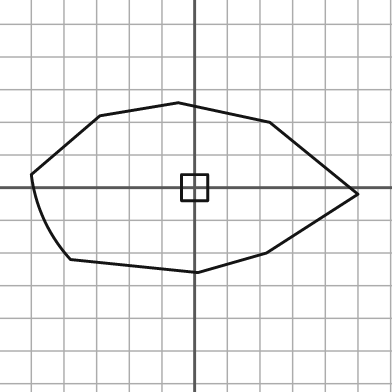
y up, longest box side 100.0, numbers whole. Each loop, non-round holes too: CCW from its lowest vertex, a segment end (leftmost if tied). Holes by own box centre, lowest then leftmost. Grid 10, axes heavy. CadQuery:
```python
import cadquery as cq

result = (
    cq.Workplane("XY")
    .moveTo(1.0, -26.0)
    .lineTo(22.0, -20.0)
    .lineTo(50.0, -2.0)
    .lineTo(23.0, 20.0)
    .lineTo(-5.0, 26.0)
    .lineTo(-29.0, 22.0)
    .lineTo(-50.0, 4.0)
    .threePointArc((-46.0, -10.0), (-38.0, -22.0))
    .close()
    .moveTo(-4.0, -4.0)
    .lineTo(4.0, -4.0)
    .lineTo(4.0, 4.0)
    .lineTo(-4.0, 4.0)
    .close()
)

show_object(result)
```